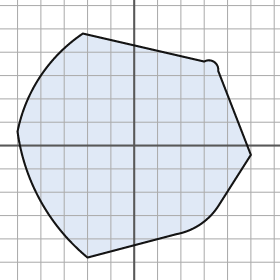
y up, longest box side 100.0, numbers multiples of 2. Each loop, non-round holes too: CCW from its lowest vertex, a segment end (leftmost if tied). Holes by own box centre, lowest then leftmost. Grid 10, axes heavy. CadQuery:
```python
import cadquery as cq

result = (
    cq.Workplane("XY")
    .moveTo(-20.0, -48.0)
    .lineTo(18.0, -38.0)
    .threePointArc((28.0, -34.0), (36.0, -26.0))
    .lineTo(50.0, -4.0)
    .lineTo(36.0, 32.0)
    .threePointArc((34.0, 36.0), (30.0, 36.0))
    .lineTo(-22.0, 48.0)
    .threePointArc((-40.0, 30.0), (-50.0, 6.0))
    .threePointArc((-40.0, -24.0), (-20.0, -48.0))
    .close()
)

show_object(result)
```